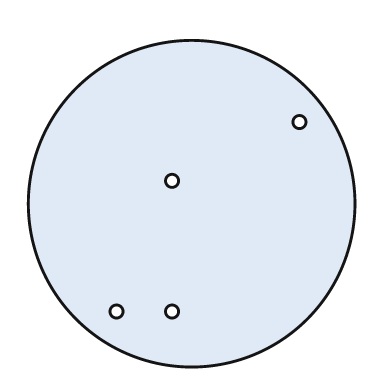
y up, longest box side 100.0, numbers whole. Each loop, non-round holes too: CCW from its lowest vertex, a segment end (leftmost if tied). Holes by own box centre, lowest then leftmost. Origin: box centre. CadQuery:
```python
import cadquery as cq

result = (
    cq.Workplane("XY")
    .moveTo(0.0, 0.0)
    .circle(50.0)
    .moveTo(-23.0, -33.0)
    .circle(2.0)
    .moveTo(-6.0, -33.0)
    .circle(2.0)
    .moveTo(-6.0, 7.0)
    .circle(2.0)
    .moveTo(33.0, 25.0)
    .circle(2.0)
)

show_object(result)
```